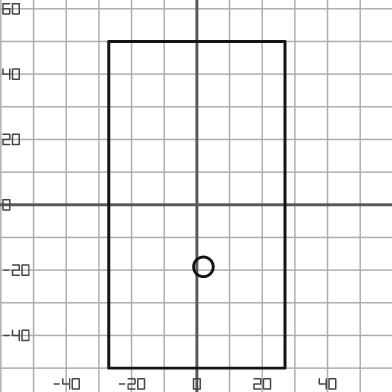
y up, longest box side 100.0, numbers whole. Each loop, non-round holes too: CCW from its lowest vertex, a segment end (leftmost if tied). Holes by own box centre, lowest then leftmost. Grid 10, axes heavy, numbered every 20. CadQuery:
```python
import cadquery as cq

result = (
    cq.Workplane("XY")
    .moveTo(-27.0, -50.0)
    .lineTo(27.0, -50.0)
    .lineTo(27.0, 50.0)
    .lineTo(-27.0, 50.0)
    .close()
    .moveTo(2.0, -19.0)
    .circle(3.0)
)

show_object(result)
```